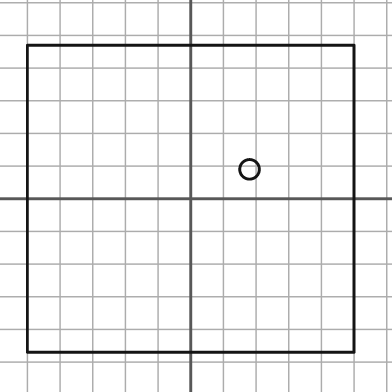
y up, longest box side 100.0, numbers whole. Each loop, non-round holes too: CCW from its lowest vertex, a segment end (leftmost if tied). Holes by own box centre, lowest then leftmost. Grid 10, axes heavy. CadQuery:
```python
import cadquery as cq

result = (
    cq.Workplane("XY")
    .moveTo(-50.0, -47.0)
    .lineTo(50.0, -47.0)
    .lineTo(50.0, 47.0)
    .lineTo(-50.0, 47.0)
    .close()
    .moveTo(18.0, 9.0)
    .circle(3.0)
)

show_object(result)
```